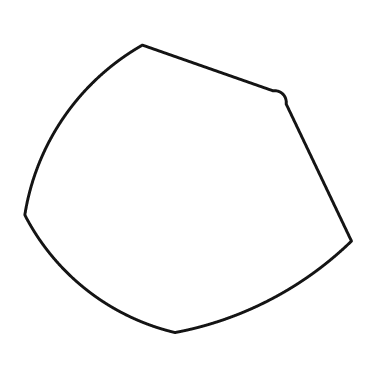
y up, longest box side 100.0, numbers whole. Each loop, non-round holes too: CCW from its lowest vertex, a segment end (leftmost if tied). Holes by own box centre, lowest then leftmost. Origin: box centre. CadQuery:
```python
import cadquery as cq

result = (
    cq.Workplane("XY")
    .moveTo(-4.0, -44.0)
    .threePointArc((25.0, -34.0), (50.0, -16.0))
    .lineTo(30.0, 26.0)
    .threePointArc((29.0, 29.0), (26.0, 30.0))
    .lineTo(-14.0, 44.0)
    .threePointArc((-38.0, 22.0), (-50.0, -8.0))
    .threePointArc((-31.0, -31.0), (-4.0, -44.0))
    .close()
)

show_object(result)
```